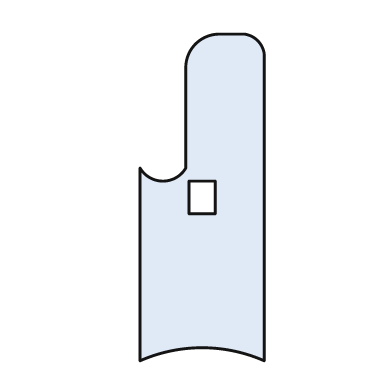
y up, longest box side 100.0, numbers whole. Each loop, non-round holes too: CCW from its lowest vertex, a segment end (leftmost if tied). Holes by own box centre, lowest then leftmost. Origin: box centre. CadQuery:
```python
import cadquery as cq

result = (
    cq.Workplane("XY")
    .moveTo(-19.0, -50.0)
    .threePointArc((0.0, -46.0), (19.0, -50.0))
    .lineTo(19.0, 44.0)
    .threePointArc((17.0, 48.0), (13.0, 50.0))
    .lineTo(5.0, 50.0)
    .threePointArc((-2.0, 47.0), (-5.0, 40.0))
    .lineTo(-5.0, 9.0)
    .threePointArc((-12.0, 5.0), (-19.0, 9.0))
    .close()
    .moveTo(-4.0, -5.0)
    .lineTo(4.0, -5.0)
    .lineTo(4.0, 5.0)
    .lineTo(-4.0, 5.0)
    .close()
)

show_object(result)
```